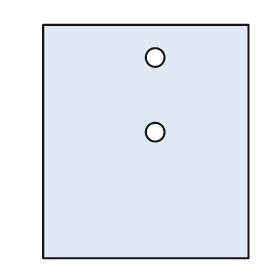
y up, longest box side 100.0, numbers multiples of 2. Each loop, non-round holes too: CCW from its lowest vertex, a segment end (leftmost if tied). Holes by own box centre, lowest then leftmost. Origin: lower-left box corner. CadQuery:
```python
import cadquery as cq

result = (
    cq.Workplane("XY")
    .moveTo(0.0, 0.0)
    .lineTo(88.0, 0.0)
    .lineTo(88.0, 100.0)
    .lineTo(0.0, 100.0)
    .close()
    .moveTo(48.0, 54.0)
    .circle(4.0)
    .moveTo(48.0, 86.0)
    .circle(4.0)
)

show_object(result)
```